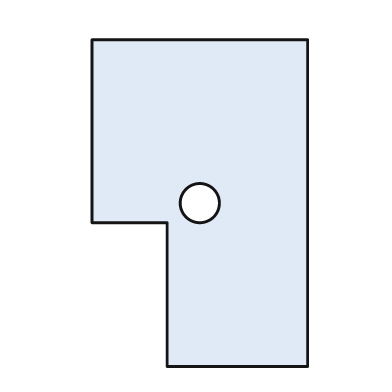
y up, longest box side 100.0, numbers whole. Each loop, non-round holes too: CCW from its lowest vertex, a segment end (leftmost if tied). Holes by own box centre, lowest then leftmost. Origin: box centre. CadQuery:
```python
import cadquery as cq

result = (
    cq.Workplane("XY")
    .moveTo(-10.0, -50.0)
    .lineTo(33.0, -50.0)
    .lineTo(33.0, 50.0)
    .lineTo(-33.0, 50.0)
    .lineTo(-33.0, -6.0)
    .lineTo(-10.0, -6.0)
    .close()
    .moveTo(0.0, 0.0)
    .circle(6.0)
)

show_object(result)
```